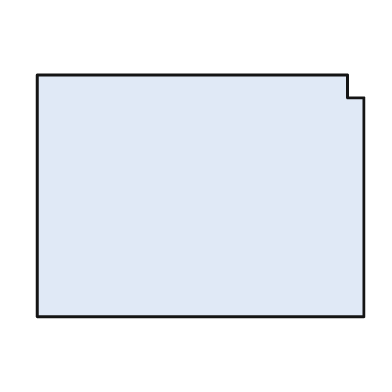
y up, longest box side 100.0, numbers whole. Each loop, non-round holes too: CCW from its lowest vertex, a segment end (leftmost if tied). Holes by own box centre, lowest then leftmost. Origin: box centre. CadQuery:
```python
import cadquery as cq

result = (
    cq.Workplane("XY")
    .moveTo(-50.0, -37.0)
    .lineTo(50.0, -37.0)
    .lineTo(50.0, 30.0)
    .lineTo(45.0, 30.0)
    .lineTo(45.0, 37.0)
    .lineTo(-50.0, 37.0)
    .close()
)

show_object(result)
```